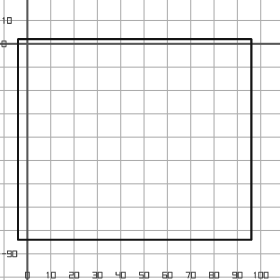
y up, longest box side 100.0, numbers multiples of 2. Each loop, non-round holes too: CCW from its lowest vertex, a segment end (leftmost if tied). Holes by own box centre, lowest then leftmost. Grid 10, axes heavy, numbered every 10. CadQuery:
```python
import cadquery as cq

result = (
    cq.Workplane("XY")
    .moveTo(-4.0, -84.0)
    .lineTo(96.0, -84.0)
    .lineTo(96.0, 2.0)
    .lineTo(-4.0, 2.0)
    .close()
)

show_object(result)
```